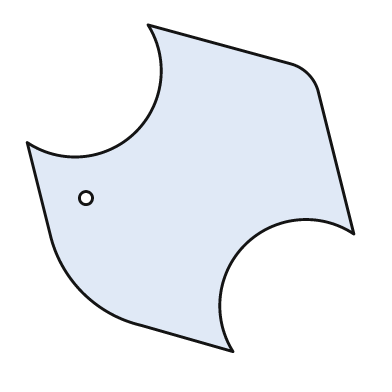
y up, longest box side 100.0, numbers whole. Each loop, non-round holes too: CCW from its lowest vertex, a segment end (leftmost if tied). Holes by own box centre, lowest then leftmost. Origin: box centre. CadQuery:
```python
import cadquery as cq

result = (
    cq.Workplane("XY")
    .moveTo(13.0, -50.0)
    .threePointArc((17.0, -17.0), (50.0, -14.0))
    .lineTo(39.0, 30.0)
    .threePointArc((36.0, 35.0), (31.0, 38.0))
    .lineTo(-13.0, 50.0)
    .threePointArc((-17.0, 17.0), (-50.0, 14.0))
    .lineTo(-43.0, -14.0)
    .threePointArc((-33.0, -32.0), (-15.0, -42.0))
    .close()
    .moveTo(-32.0, -3.0)
    .circle(2.0)
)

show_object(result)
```